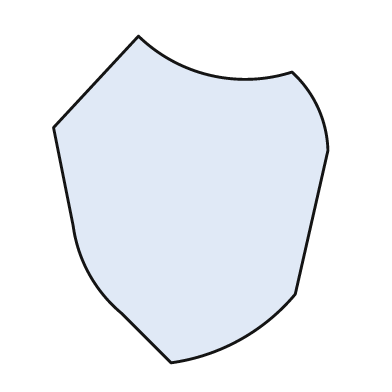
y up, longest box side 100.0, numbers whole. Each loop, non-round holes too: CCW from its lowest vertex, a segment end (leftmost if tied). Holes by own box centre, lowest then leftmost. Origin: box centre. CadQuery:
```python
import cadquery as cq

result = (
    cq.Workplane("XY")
    .moveTo(-6.0, -50.0)
    .threePointArc((15.0, -43.0), (32.0, -29.0))
    .lineTo(42.0, 15.0)
    .threePointArc((39.0, 28.0), (31.0, 39.0))
    .threePointArc((6.0, 38.0), (-16.0, 50.0))
    .lineTo(-42.0, 22.0)
    .lineTo(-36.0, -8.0)
    .threePointArc((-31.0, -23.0), (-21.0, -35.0))
    .close()
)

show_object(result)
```